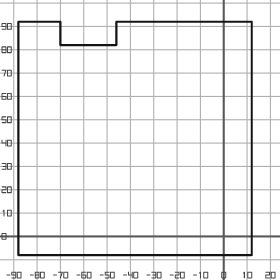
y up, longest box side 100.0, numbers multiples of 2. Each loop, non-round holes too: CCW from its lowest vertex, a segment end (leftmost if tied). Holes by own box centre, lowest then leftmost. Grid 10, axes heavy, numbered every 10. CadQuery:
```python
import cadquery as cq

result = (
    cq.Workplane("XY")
    .moveTo(-88.0, -8.0)
    .lineTo(12.0, -8.0)
    .lineTo(12.0, 92.0)
    .lineTo(-46.0, 92.0)
    .lineTo(-46.0, 82.0)
    .lineTo(-70.0, 82.0)
    .lineTo(-70.0, 92.0)
    .lineTo(-88.0, 92.0)
    .close()
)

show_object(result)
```